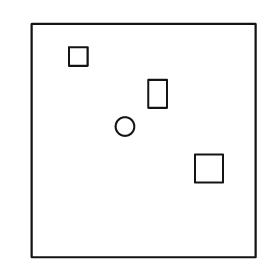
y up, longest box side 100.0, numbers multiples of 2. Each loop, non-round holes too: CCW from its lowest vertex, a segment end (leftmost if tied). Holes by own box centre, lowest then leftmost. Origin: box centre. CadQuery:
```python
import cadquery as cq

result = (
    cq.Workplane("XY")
    .moveTo(-48.0, -50.0)
    .lineTo(48.0, -50.0)
    .lineTo(48.0, 50.0)
    .lineTo(-48.0, 50.0)
    .close()
    .moveTo(22.0, -18.0)
    .lineTo(34.0, -18.0)
    .lineTo(34.0, -6.0)
    .lineTo(22.0, -6.0)
    .close()
    .moveTo(-8.0, 6.0)
    .circle(4.0)
    .moveTo(2.0, 14.0)
    .lineTo(10.0, 14.0)
    .lineTo(10.0, 26.0)
    .lineTo(2.0, 26.0)
    .close()
    .moveTo(-32.0, 32.0)
    .lineTo(-24.0, 32.0)
    .lineTo(-24.0, 40.0)
    .lineTo(-32.0, 40.0)
    .close()
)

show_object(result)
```